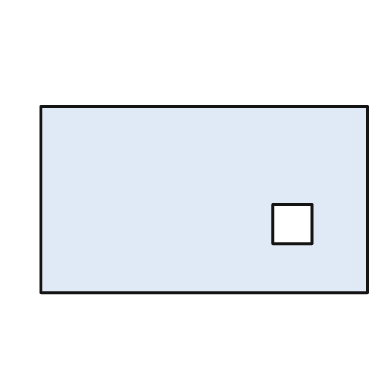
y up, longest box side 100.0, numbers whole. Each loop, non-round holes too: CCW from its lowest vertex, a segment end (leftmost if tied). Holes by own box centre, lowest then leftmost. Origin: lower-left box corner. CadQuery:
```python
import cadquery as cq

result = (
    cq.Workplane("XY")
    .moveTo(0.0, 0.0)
    .lineTo(100.0, 0.0)
    .lineTo(100.0, 57.0)
    .lineTo(0.0, 57.0)
    .close()
    .moveTo(71.0, 15.0)
    .lineTo(83.0, 15.0)
    .lineTo(83.0, 27.0)
    .lineTo(71.0, 27.0)
    .close()
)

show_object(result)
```